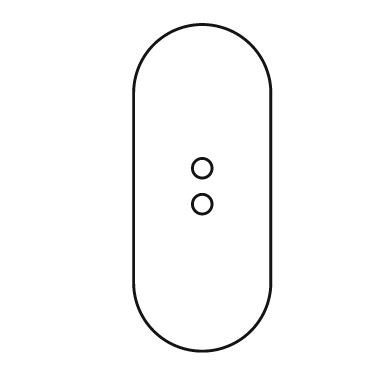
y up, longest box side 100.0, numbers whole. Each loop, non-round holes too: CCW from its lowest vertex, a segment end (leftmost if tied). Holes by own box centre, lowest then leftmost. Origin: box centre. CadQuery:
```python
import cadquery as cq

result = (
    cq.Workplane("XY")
    .moveTo(-21.0, -29.0)
    .threePointArc((0.0, -50.0), (21.0, -29.0))
    .lineTo(21.0, 29.0)
    .threePointArc((0.0, 50.0), (-21.0, 29.0))
    .close()
    .moveTo(0.0, -5.0)
    .circle(3.0)
    .moveTo(0.0, 6.0)
    .circle(3.0)
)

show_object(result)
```